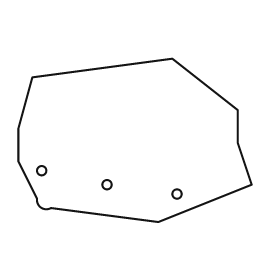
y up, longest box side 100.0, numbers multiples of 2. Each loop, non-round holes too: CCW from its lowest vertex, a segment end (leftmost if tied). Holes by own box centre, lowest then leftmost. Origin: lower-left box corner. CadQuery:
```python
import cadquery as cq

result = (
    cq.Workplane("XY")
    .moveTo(60.0, 0.0)
    .lineTo(100.0, 16.0)
    .lineTo(94.0, 34.0)
    .lineTo(94.0, 48.0)
    .lineTo(66.0, 70.0)
    .lineTo(6.0, 62.0)
    .lineTo(0.0, 40.0)
    .lineTo(0.0, 26.0)
    .lineTo(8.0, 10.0)
    .threePointArc((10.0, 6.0), (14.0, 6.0))
    .close()
    .moveTo(68.0, 12.0)
    .circle(2.0)
    .moveTo(38.0, 16.0)
    .circle(2.0)
    .moveTo(10.0, 22.0)
    .circle(2.0)
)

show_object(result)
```